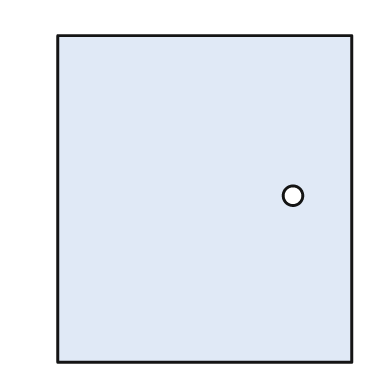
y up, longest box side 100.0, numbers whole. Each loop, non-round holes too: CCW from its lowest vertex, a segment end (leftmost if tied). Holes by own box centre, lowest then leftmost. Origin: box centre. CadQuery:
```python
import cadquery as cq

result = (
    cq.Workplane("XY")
    .moveTo(-45.0, -50.0)
    .lineTo(45.0, -50.0)
    .lineTo(45.0, 50.0)
    .lineTo(-45.0, 50.0)
    .close()
    .moveTo(27.0, 1.0)
    .circle(3.0)
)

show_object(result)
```